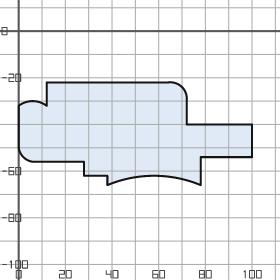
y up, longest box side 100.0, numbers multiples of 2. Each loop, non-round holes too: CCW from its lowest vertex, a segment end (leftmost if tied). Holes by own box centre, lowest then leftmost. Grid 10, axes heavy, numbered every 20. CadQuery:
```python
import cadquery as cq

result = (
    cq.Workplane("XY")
    .moveTo(38.0, -66.0)
    .threePointArc((58.0, -62.0), (78.0, -66.0))
    .lineTo(78.0, -54.0)
    .lineTo(100.0, -54.0)
    .lineTo(100.0, -40.0)
    .lineTo(72.0, -40.0)
    .lineTo(72.0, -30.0)
    .threePointArc((70.0, -24.0), (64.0, -22.0))
    .lineTo(12.0, -22.0)
    .lineTo(12.0, -32.0)
    .threePointArc((6.0, -30.0), (0.0, -32.0))
    .lineTo(0.0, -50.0)
    .threePointArc((2.0, -54.0), (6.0, -56.0))
    .lineTo(28.0, -56.0)
    .lineTo(28.0, -62.0)
    .lineTo(38.0, -62.0)
    .close()
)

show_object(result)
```